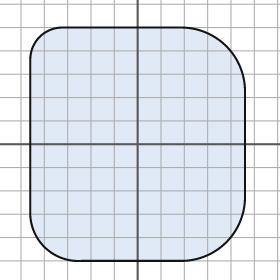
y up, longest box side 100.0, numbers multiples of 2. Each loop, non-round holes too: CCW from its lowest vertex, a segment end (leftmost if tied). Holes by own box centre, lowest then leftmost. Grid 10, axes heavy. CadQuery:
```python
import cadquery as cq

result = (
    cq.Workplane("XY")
    .moveTo(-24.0, -50.0)
    .lineTo(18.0, -50.0)
    .threePointArc((38.0, -42.0), (46.0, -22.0))
    .lineTo(46.0, 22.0)
    .threePointArc((38.0, 42.0), (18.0, 50.0))
    .lineTo(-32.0, 50.0)
    .threePointArc((-42.0, 46.0), (-46.0, 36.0))
    .lineTo(-46.0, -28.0)
    .threePointArc((-40.0, -44.0), (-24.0, -50.0))
    .close()
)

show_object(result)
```